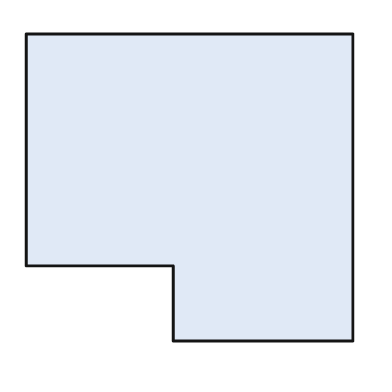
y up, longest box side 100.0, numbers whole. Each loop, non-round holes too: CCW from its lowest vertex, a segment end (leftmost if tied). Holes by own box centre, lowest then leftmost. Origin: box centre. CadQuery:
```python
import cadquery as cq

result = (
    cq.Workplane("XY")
    .moveTo(-5.0, -47.0)
    .lineTo(50.0, -47.0)
    .lineTo(50.0, 47.0)
    .lineTo(-50.0, 47.0)
    .lineTo(-50.0, -24.0)
    .lineTo(-5.0, -24.0)
    .close()
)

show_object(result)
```